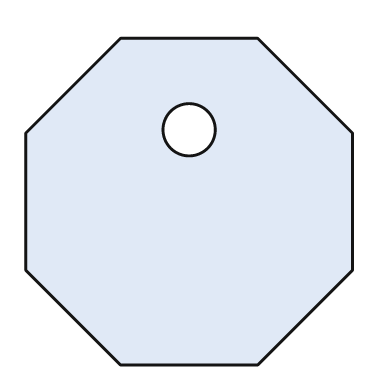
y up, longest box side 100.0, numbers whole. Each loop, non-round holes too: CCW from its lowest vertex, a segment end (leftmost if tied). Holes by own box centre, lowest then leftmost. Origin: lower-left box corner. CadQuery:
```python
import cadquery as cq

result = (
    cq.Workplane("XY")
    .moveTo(29.0, 0.0)
    .lineTo(71.0, 0.0)
    .lineTo(100.0, 29.0)
    .lineTo(100.0, 71.0)
    .lineTo(71.0, 100.0)
    .lineTo(29.0, 100.0)
    .lineTo(0.0, 71.0)
    .lineTo(0.0, 29.0)
    .close()
    .moveTo(50.0, 72.0)
    .circle(8.0)
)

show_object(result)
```